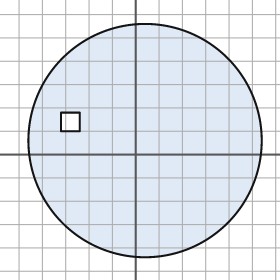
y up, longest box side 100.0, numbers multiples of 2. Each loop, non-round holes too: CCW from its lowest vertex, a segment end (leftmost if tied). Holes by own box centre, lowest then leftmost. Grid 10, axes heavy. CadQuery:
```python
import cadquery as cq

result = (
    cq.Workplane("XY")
    .moveTo(4.0, 6.0)
    .circle(50.0)
    .moveTo(-32.0, 10.0)
    .lineTo(-24.0, 10.0)
    .lineTo(-24.0, 18.0)
    .lineTo(-32.0, 18.0)
    .close()
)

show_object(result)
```